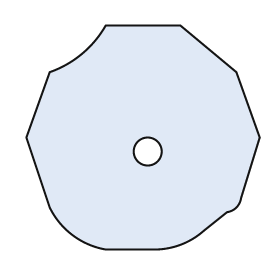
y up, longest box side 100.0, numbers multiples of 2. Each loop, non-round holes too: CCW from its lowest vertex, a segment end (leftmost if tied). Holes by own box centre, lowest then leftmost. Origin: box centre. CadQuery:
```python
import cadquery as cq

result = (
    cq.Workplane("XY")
    .moveTo(-16.0, -48.0)
    .lineTo(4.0, -48.0)
    .threePointArc((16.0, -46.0), (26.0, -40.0))
    .lineTo(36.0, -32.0)
    .threePointArc((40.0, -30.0), (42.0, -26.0))
    .lineTo(50.0, 0.0)
    .lineTo(40.0, 28.0)
    .lineTo(16.0, 48.0)
    .lineTo(-16.0, 48.0)
    .threePointArc((-26.0, 36.0), (-40.0, 28.0))
    .lineTo(-50.0, 0.0)
    .lineTo(-40.0, -30.0)
    .threePointArc((-30.0, -42.0), (-16.0, -48.0))
    .close()
    .moveTo(2.0, -6.0)
    .circle(6.0)
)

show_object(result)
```